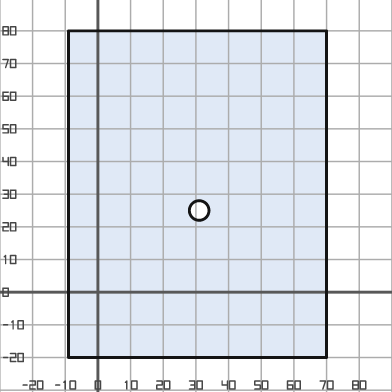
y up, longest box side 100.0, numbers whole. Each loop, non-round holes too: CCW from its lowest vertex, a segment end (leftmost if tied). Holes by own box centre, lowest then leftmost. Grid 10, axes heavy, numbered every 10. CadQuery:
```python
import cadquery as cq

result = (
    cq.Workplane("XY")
    .moveTo(-9.0, -20.0)
    .lineTo(70.0, -20.0)
    .lineTo(70.0, 80.0)
    .lineTo(-9.0, 80.0)
    .close()
    .moveTo(31.0, 25.0)
    .circle(3.0)
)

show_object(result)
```